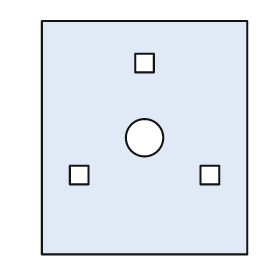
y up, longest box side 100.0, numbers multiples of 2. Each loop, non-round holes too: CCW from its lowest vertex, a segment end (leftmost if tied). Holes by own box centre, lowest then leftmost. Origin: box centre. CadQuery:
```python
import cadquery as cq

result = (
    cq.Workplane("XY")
    .moveTo(-44.0, -50.0)
    .lineTo(44.0, -50.0)
    .lineTo(44.0, 50.0)
    .lineTo(-44.0, 50.0)
    .close()
    .moveTo(-32.0, -20.0)
    .lineTo(-24.0, -20.0)
    .lineTo(-24.0, -12.0)
    .lineTo(-32.0, -12.0)
    .close()
    .moveTo(24.0, -20.0)
    .lineTo(32.0, -20.0)
    .lineTo(32.0, -12.0)
    .lineTo(24.0, -12.0)
    .close()
    .moveTo(0.0, 0.0)
    .circle(8.0)
    .moveTo(-4.0, 28.0)
    .lineTo(4.0, 28.0)
    .lineTo(4.0, 36.0)
    .lineTo(-4.0, 36.0)
    .close()
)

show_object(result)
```